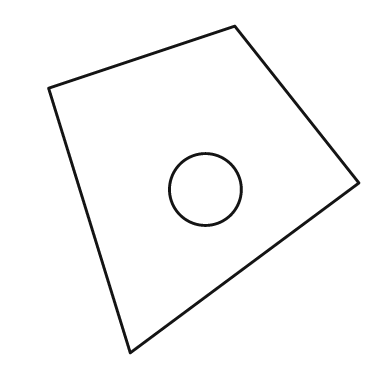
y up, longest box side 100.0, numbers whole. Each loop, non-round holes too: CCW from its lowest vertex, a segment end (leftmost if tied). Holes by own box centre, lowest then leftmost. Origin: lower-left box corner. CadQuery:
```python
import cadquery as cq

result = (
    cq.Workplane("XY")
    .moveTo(25.0, 0.0)
    .lineTo(95.0, 52.0)
    .lineTo(57.0, 100.0)
    .lineTo(0.0, 81.0)
    .close()
    .moveTo(48.0, 50.0)
    .circle(11.0)
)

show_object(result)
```